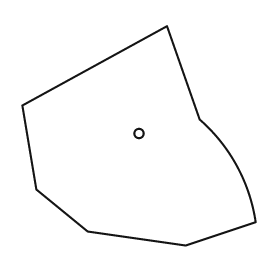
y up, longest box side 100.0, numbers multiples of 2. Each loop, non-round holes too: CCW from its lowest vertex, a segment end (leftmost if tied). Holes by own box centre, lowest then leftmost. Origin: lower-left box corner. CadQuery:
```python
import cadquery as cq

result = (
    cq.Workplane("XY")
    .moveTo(70.0, 0.0)
    .lineTo(100.0, 10.0)
    .threePointArc((92.0, 34.0), (76.0, 54.0))
    .lineTo(62.0, 94.0)
    .lineTo(0.0, 60.0)
    .lineTo(6.0, 24.0)
    .lineTo(28.0, 6.0)
    .close()
    .moveTo(50.0, 48.0)
    .circle(2.0)
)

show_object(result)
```